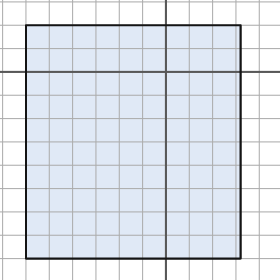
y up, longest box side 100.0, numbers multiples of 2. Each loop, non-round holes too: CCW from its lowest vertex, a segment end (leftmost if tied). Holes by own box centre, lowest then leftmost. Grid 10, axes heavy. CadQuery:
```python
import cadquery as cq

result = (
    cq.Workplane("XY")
    .moveTo(-60.0, -80.0)
    .lineTo(32.0, -80.0)
    .lineTo(32.0, 20.0)
    .lineTo(-60.0, 20.0)
    .close()
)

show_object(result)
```